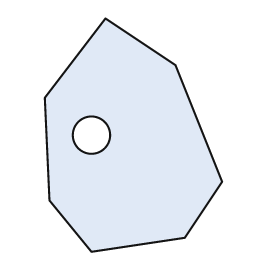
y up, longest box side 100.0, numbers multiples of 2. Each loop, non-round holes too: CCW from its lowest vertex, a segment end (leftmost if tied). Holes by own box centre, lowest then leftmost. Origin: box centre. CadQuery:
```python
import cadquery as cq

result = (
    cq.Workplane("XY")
    .moveTo(-18.0, -50.0)
    .lineTo(22.0, -44.0)
    .lineTo(38.0, -20.0)
    .lineTo(18.0, 30.0)
    .lineTo(-12.0, 50.0)
    .lineTo(-38.0, 16.0)
    .lineTo(-36.0, -28.0)
    .close()
    .moveTo(-18.0, 0.0)
    .circle(8.0)
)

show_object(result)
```